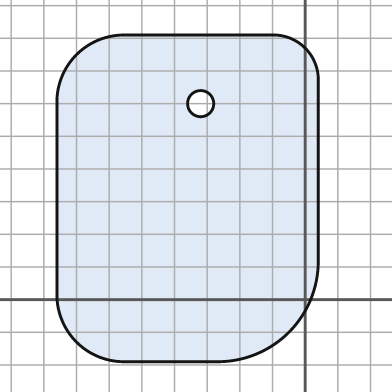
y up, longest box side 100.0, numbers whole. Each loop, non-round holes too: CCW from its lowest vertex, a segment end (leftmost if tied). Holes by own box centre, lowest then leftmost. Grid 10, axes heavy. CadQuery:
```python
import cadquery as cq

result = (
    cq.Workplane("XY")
    .moveTo(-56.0, -19.0)
    .lineTo(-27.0, -19.0)
    .threePointArc((-5.0, -10.0), (4.0, 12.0))
    .lineTo(4.0, 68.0)
    .threePointArc((0.0, 77.0), (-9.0, 81.0))
    .lineTo(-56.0, 81.0)
    .threePointArc((-70.0, 75.0), (-76.0, 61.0))
    .lineTo(-76.0, 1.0)
    .threePointArc((-70.0, -13.0), (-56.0, -19.0))
    .close()
    .moveTo(-32.0, 60.0)
    .circle(4.0)
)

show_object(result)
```